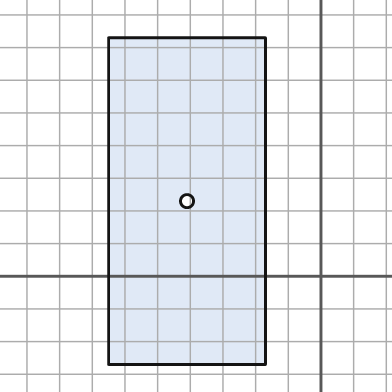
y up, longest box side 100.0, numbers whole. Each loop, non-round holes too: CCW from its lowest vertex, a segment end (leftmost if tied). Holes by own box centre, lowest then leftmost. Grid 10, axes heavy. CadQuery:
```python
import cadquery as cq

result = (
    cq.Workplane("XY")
    .moveTo(-65.0, -27.0)
    .lineTo(-17.0, -27.0)
    .lineTo(-17.0, 73.0)
    .lineTo(-65.0, 73.0)
    .close()
    .moveTo(-41.0, 23.0)
    .circle(2.0)
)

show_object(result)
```